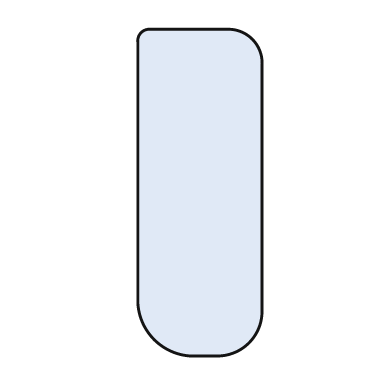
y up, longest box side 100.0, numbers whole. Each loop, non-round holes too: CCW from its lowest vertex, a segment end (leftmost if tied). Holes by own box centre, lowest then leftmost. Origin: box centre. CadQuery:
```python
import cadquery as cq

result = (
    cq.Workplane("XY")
    .moveTo(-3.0, -50.0)
    .lineTo(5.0, -50.0)
    .threePointArc((15.0, -46.0), (19.0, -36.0))
    .lineTo(19.0, 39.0)
    .threePointArc((16.0, 47.0), (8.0, 50.0))
    .lineTo(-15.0, 50.0)
    .threePointArc((-18.0, 49.0), (-19.0, 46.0))
    .lineTo(-19.0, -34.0)
    .threePointArc((-14.0, -45.0), (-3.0, -50.0))
    .close()
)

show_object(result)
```